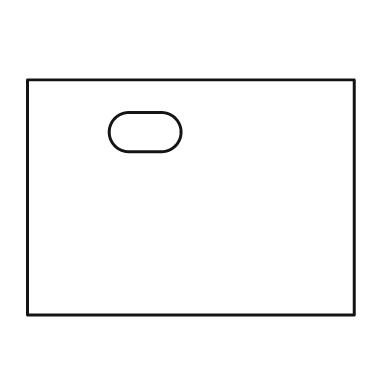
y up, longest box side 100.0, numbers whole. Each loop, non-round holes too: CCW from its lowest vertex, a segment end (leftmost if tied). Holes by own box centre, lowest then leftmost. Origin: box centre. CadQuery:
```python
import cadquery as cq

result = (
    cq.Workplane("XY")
    .moveTo(-50.0, -36.0)
    .lineTo(50.0, -36.0)
    .lineTo(50.0, 36.0)
    .lineTo(-50.0, 36.0)
    .close()
    .moveTo(-19.0, 14.0)
    .lineTo(-9.0, 14.0)
    .threePointArc((-3.0, 20.0), (-9.0, 26.0))
    .lineTo(-19.0, 26.0)
    .threePointArc((-25.0, 20.0), (-19.0, 14.0))
    .close()
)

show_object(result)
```